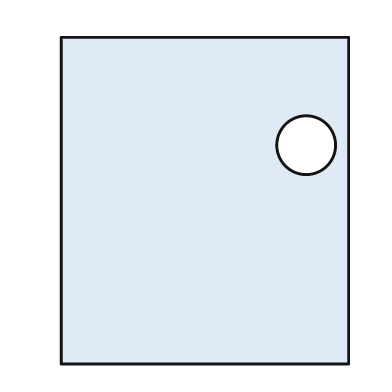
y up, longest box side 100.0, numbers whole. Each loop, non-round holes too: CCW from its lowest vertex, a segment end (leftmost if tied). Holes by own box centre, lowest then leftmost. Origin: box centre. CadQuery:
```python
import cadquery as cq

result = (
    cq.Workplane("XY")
    .moveTo(-44.0, -50.0)
    .lineTo(44.0, -50.0)
    .lineTo(44.0, 50.0)
    .lineTo(-44.0, 50.0)
    .close()
    .moveTo(31.0, 17.0)
    .circle(9.0)
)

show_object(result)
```